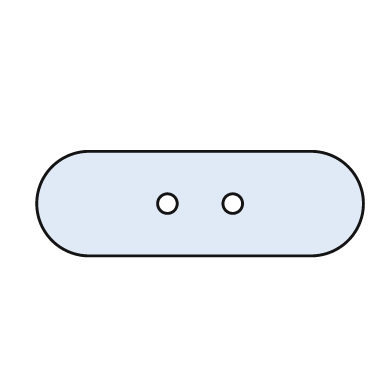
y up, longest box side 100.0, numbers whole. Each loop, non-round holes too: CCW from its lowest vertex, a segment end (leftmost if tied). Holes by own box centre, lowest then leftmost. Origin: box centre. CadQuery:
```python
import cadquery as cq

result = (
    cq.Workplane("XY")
    .moveTo(-34.0, -16.0)
    .lineTo(34.0, -16.0)
    .threePointArc((50.0, 0.0), (34.0, 16.0))
    .lineTo(-34.0, 16.0)
    .threePointArc((-50.0, 0.0), (-34.0, -16.0))
    .close()
    .moveTo(-10.0, 0.0)
    .circle(3.0)
    .moveTo(10.0, 0.0)
    .circle(3.0)
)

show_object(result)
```